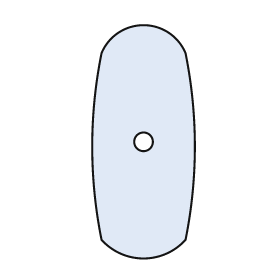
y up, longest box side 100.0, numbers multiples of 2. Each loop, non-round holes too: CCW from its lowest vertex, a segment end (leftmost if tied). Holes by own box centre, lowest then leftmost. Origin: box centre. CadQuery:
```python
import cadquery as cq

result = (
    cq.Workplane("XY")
    .moveTo(-18.0, -42.0)
    .threePointArc((0.0, -50.0), (18.0, -42.0))
    .threePointArc((22.0, -2.0), (18.0, 38.0))
    .threePointArc((0.0, 50.0), (-18.0, 38.0))
    .threePointArc((-22.0, -2.0), (-18.0, -42.0))
    .close()
    .moveTo(0.0, 0.0)
    .circle(4.0)
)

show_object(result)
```